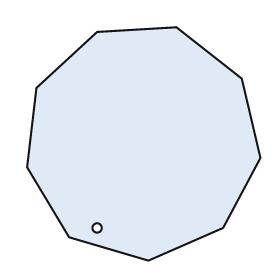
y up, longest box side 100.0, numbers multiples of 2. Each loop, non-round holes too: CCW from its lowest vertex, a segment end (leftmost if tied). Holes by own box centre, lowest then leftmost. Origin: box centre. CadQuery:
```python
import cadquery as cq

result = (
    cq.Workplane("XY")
    .moveTo(2.0, -50.0)
    .lineTo(34.0, -36.0)
    .lineTo(50.0, -6.0)
    .lineTo(42.0, 28.0)
    .lineTo(14.0, 50.0)
    .lineTo(-20.0, 48.0)
    .lineTo(-46.0, 24.0)
    .lineTo(-50.0, -10.0)
    .lineTo(-32.0, -40.0)
    .close()
    .moveTo(-20.0, -36.0)
    .circle(2.0)
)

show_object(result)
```